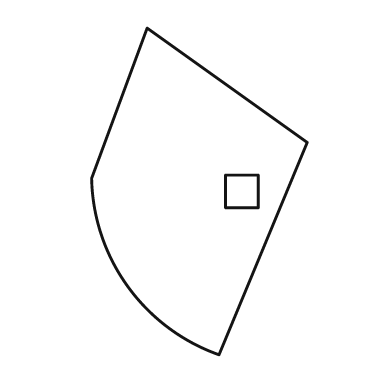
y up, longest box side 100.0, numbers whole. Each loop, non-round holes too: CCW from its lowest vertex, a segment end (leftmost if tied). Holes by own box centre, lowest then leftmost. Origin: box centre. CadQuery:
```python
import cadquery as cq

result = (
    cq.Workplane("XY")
    .moveTo(6.0, -50.0)
    .lineTo(33.0, 15.0)
    .lineTo(-16.0, 50.0)
    .lineTo(-33.0, 4.0)
    .threePointArc((-22.0, -29.0), (6.0, -50.0))
    .close()
    .moveTo(8.0, -5.0)
    .lineTo(18.0, -5.0)
    .lineTo(18.0, 5.0)
    .lineTo(8.0, 5.0)
    .close()
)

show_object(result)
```